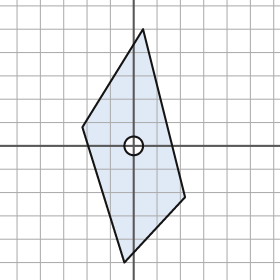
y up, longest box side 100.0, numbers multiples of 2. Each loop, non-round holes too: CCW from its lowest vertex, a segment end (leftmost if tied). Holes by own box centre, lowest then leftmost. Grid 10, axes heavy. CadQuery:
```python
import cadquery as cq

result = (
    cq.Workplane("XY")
    .moveTo(-4.0, -50.0)
    .lineTo(22.0, -22.0)
    .lineTo(4.0, 50.0)
    .lineTo(-22.0, 8.0)
    .close()
    .moveTo(0.0, 0.0)
    .circle(4.0)
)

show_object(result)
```